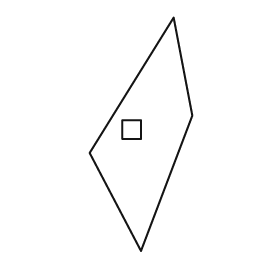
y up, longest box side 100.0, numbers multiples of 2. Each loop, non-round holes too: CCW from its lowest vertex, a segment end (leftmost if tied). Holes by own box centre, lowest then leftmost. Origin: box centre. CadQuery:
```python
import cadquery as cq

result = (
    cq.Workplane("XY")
    .moveTo(0.0, -50.0)
    .lineTo(22.0, 8.0)
    .lineTo(14.0, 50.0)
    .lineTo(-22.0, -8.0)
    .close()
    .moveTo(-8.0, -2.0)
    .lineTo(0.0, -2.0)
    .lineTo(0.0, 6.0)
    .lineTo(-8.0, 6.0)
    .close()
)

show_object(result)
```